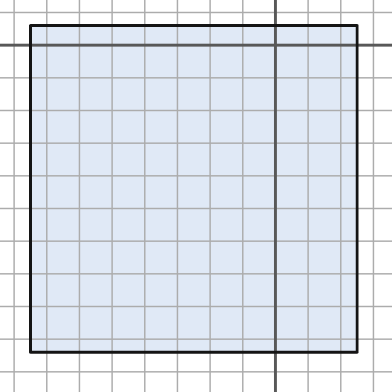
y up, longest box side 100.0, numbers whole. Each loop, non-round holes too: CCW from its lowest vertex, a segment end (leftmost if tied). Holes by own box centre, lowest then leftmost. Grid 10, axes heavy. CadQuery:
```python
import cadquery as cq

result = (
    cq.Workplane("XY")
    .moveTo(-75.0, -94.0)
    .lineTo(25.0, -94.0)
    .lineTo(25.0, 6.0)
    .lineTo(-75.0, 6.0)
    .close()
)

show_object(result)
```